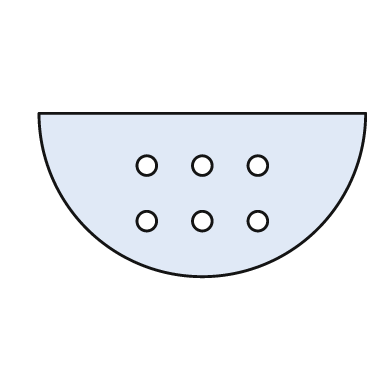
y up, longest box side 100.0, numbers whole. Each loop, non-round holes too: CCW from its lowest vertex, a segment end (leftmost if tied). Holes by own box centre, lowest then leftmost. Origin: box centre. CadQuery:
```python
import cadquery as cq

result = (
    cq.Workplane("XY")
    .moveTo(-50.0, 25.0)
    .threePointArc((0.0, -25.0), (50.0, 25.0))
    .close()
    .moveTo(-17.0, -8.0)
    .circle(3.0)
    .moveTo(0.0, -8.0)
    .circle(3.0)
    .moveTo(17.0, -8.0)
    .circle(3.0)
    .moveTo(-17.0, 9.0)
    .circle(3.0)
    .moveTo(0.0, 9.0)
    .circle(3.0)
    .moveTo(17.0, 9.0)
    .circle(3.0)
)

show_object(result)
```